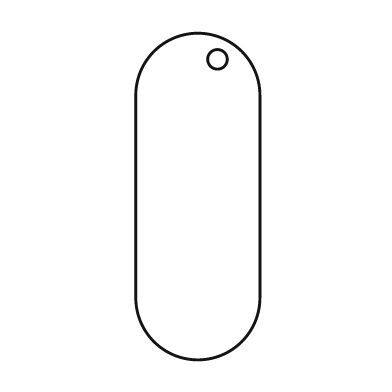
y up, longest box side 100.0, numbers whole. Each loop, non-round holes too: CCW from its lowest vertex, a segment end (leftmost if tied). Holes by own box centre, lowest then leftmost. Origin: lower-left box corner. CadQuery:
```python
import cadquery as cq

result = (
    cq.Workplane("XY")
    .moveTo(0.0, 19.0)
    .threePointArc((19.0, 0.0), (38.0, 19.0))
    .lineTo(38.0, 81.0)
    .threePointArc((19.0, 100.0), (0.0, 81.0))
    .close()
    .moveTo(25.0, 92.0)
    .circle(3.0)
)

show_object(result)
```